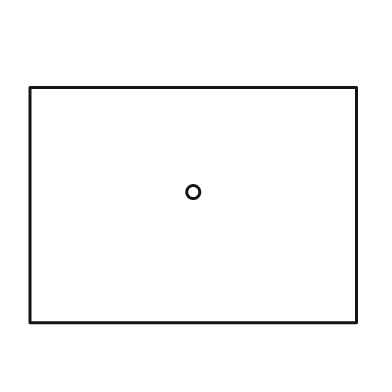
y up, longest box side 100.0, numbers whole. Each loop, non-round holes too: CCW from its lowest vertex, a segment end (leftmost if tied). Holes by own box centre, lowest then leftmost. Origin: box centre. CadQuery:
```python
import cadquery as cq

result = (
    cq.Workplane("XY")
    .moveTo(-50.0, -36.0)
    .lineTo(50.0, -36.0)
    .lineTo(50.0, 36.0)
    .lineTo(-50.0, 36.0)
    .close()
    .moveTo(0.0, 4.0)
    .circle(2.0)
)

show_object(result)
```